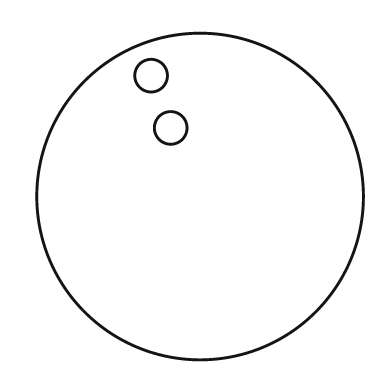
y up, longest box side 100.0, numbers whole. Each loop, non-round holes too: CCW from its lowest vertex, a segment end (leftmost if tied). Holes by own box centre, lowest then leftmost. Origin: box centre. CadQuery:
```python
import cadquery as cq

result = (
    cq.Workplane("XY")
    .moveTo(0.0, 0.0)
    .circle(50.0)
    .moveTo(-9.0, 21.0)
    .circle(5.0)
    .moveTo(-15.0, 37.0)
    .circle(5.0)
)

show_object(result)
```